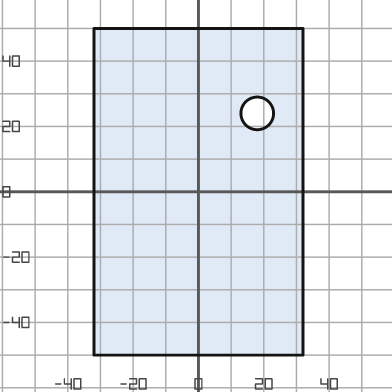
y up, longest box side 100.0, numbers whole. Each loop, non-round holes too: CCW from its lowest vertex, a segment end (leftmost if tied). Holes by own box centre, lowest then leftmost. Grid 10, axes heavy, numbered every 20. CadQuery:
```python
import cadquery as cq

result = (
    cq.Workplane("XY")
    .moveTo(-32.0, -50.0)
    .lineTo(32.0, -50.0)
    .lineTo(32.0, 50.0)
    .lineTo(-32.0, 50.0)
    .close()
    .moveTo(18.0, 24.0)
    .circle(5.0)
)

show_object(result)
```